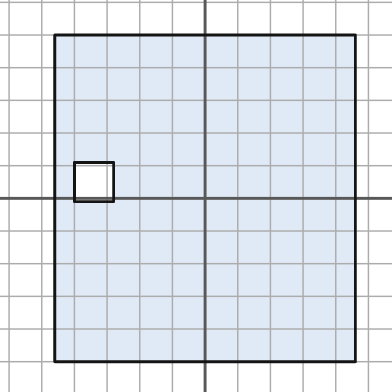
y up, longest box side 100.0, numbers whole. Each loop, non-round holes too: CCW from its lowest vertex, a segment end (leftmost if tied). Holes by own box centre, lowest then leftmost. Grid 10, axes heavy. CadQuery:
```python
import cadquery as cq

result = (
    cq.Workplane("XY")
    .moveTo(-46.0, -50.0)
    .lineTo(46.0, -50.0)
    .lineTo(46.0, 50.0)
    .lineTo(-46.0, 50.0)
    .close()
    .moveTo(-40.0, -1.0)
    .lineTo(-28.0, -1.0)
    .lineTo(-28.0, 11.0)
    .lineTo(-40.0, 11.0)
    .close()
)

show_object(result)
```